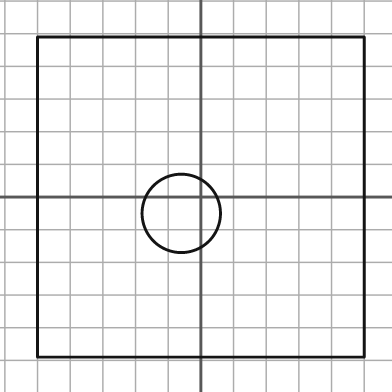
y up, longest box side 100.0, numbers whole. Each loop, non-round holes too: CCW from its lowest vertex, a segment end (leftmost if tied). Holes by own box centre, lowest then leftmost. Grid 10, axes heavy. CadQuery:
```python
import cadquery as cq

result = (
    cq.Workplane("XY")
    .moveTo(-50.0, -49.0)
    .lineTo(50.0, -49.0)
    .lineTo(50.0, 49.0)
    .lineTo(-50.0, 49.0)
    .close()
    .moveTo(-6.0, -5.0)
    .circle(12.0)
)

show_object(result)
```